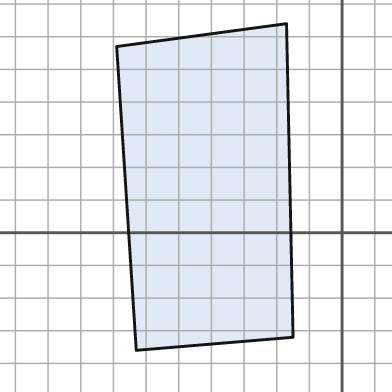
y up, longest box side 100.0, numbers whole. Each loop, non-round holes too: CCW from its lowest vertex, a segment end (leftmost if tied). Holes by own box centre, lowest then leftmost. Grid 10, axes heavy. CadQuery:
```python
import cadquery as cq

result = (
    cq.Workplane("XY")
    .moveTo(-63.0, -36.0)
    .lineTo(-15.0, -32.0)
    .lineTo(-17.0, 64.0)
    .lineTo(-69.0, 57.0)
    .close()
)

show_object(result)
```